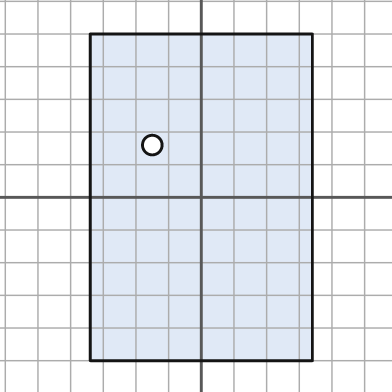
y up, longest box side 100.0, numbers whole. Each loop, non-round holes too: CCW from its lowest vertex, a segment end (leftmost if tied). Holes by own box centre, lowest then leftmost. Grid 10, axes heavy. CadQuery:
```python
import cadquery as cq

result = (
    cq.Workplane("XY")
    .moveTo(-34.0, -50.0)
    .lineTo(34.0, -50.0)
    .lineTo(34.0, 50.0)
    .lineTo(-34.0, 50.0)
    .close()
    .moveTo(-15.0, 16.0)
    .circle(3.0)
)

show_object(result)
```